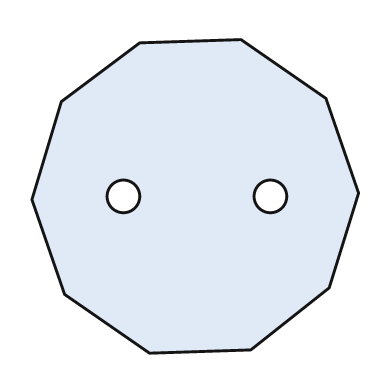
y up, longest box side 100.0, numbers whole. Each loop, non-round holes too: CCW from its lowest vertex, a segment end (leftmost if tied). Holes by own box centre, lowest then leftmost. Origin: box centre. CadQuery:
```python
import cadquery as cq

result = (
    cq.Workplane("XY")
    .moveTo(-14.0, -48.0)
    .lineTo(17.0, -47.0)
    .lineTo(41.0, -28.0)
    .lineTo(50.0, 1.0)
    .lineTo(40.0, 30.0)
    .lineTo(14.0, 48.0)
    .lineTo(-17.0, 47.0)
    .lineTo(-41.0, 29.0)
    .lineTo(-50.0, -1.0)
    .lineTo(-40.0, -30.0)
    .close()
    .moveTo(-22.0, 0.0)
    .circle(5.0)
    .moveTo(23.0, 0.0)
    .circle(5.0)
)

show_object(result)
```